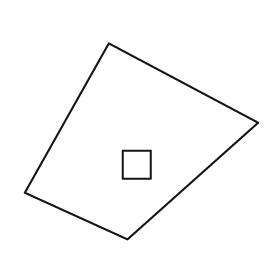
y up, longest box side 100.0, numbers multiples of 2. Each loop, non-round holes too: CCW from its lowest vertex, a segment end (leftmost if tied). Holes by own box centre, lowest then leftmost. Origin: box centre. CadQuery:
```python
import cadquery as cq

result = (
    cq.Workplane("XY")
    .moveTo(-6.0, -42.0)
    .lineTo(50.0, 8.0)
    .lineTo(-14.0, 42.0)
    .lineTo(-50.0, -22.0)
    .close()
    .moveTo(-8.0, -16.0)
    .lineTo(4.0, -16.0)
    .lineTo(4.0, -4.0)
    .lineTo(-8.0, -4.0)
    .close()
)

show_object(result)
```